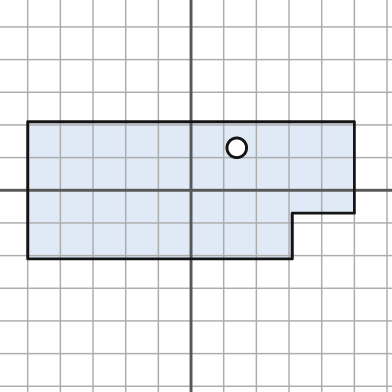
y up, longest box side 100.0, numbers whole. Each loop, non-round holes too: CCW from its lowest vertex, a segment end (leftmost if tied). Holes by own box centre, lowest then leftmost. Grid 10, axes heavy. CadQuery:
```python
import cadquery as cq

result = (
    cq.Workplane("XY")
    .moveTo(-50.0, -21.0)
    .lineTo(31.0, -21.0)
    .lineTo(31.0, -7.0)
    .lineTo(50.0, -7.0)
    .lineTo(50.0, 21.0)
    .lineTo(-50.0, 21.0)
    .close()
    .moveTo(14.0, 13.0)
    .circle(3.0)
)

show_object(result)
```